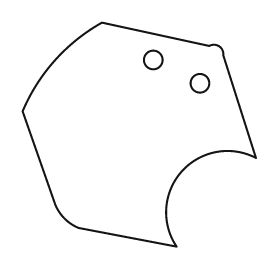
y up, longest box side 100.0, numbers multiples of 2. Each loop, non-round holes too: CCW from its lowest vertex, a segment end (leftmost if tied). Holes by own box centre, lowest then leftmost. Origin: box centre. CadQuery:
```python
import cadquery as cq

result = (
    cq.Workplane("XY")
    .moveTo(16.0, -48.0)
    .threePointArc((18.0, -16.0), (50.0, -10.0))
    .lineTo(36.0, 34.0)
    .threePointArc((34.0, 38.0), (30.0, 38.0))
    .lineTo(-16.0, 48.0)
    .threePointArc((-36.0, 32.0), (-50.0, 10.0))
    .lineTo(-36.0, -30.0)
    .threePointArc((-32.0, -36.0), (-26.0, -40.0))
    .close()
    .moveTo(26.0, 22.0)
    .circle(4.0)
    .moveTo(6.0, 32.0)
    .circle(4.0)
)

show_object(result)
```